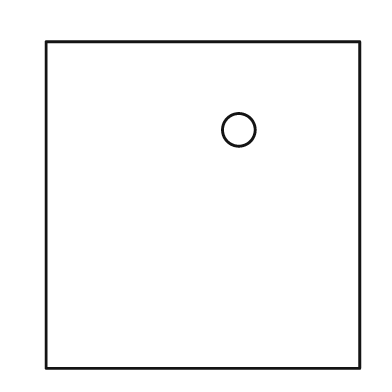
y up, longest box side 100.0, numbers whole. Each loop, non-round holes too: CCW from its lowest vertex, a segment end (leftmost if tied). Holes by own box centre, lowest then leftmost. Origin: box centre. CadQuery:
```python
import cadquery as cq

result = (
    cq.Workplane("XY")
    .moveTo(-48.0, -50.0)
    .lineTo(48.0, -50.0)
    .lineTo(48.0, 50.0)
    .lineTo(-48.0, 50.0)
    .close()
    .moveTo(11.0, 23.0)
    .circle(5.0)
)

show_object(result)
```